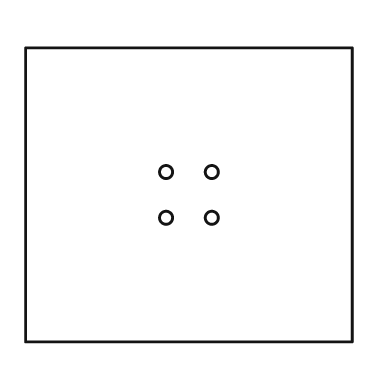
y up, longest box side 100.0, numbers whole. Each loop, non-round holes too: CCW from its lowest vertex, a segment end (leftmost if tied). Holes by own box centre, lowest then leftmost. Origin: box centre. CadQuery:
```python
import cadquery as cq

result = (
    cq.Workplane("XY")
    .moveTo(-50.0, -45.0)
    .lineTo(50.0, -45.0)
    .lineTo(50.0, 45.0)
    .lineTo(-50.0, 45.0)
    .close()
    .moveTo(-7.0, -7.0)
    .circle(2.0)
    .moveTo(7.0, -7.0)
    .circle(2.0)
    .moveTo(-7.0, 7.0)
    .circle(2.0)
    .moveTo(7.0, 7.0)
    .circle(2.0)
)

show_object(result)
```